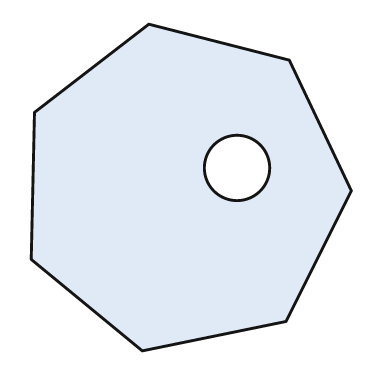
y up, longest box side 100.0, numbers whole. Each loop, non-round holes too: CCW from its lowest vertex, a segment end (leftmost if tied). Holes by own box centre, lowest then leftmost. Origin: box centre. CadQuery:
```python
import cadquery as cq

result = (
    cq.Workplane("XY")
    .moveTo(-15.0, -50.0)
    .lineTo(29.0, -41.0)
    .lineTo(49.0, -1.0)
    .lineTo(30.0, 39.0)
    .lineTo(-13.0, 50.0)
    .lineTo(-48.0, 23.0)
    .lineTo(-49.0, -22.0)
    .close()
    .moveTo(14.0, 6.0)
    .circle(10.0)
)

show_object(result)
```